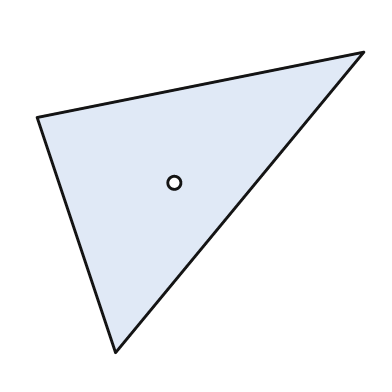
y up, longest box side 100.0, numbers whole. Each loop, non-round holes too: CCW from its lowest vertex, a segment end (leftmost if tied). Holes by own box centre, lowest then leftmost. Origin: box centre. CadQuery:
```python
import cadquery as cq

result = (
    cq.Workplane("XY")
    .moveTo(-26.0, -46.0)
    .lineTo(50.0, 46.0)
    .lineTo(-50.0, 26.0)
    .close()
    .moveTo(-8.0, 6.0)
    .circle(2.0)
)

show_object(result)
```